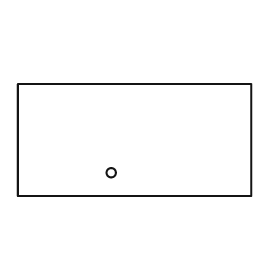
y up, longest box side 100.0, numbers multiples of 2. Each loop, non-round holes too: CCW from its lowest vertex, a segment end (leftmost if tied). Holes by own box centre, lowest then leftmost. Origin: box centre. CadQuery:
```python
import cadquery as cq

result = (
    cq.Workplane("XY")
    .moveTo(-50.0, -24.0)
    .lineTo(50.0, -24.0)
    .lineTo(50.0, 24.0)
    .lineTo(-50.0, 24.0)
    .close()
    .moveTo(-10.0, -14.0)
    .circle(2.0)
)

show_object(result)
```